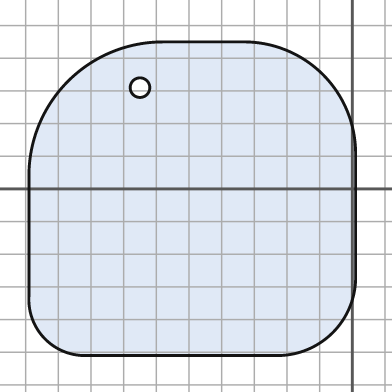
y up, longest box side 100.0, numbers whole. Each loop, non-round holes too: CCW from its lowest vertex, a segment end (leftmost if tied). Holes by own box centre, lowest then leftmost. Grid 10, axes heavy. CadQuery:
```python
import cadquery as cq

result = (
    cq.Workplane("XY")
    .moveTo(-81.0, -51.0)
    .lineTo(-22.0, -51.0)
    .threePointArc((-6.0, -44.0), (1.0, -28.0))
    .lineTo(1.0, 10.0)
    .threePointArc((-9.0, 35.0), (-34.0, 45.0))
    .lineTo(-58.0, 45.0)
    .threePointArc((-87.0, 33.0), (-99.0, 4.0))
    .lineTo(-99.0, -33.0)
    .threePointArc((-94.0, -46.0), (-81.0, -51.0))
    .close()
    .moveTo(-65.0, 31.0)
    .circle(3.0)
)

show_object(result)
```